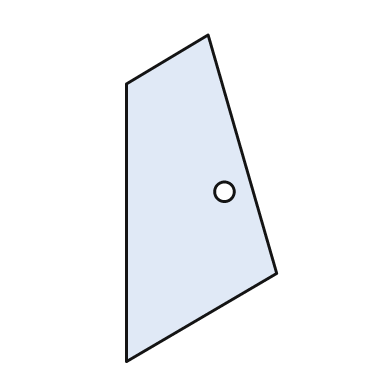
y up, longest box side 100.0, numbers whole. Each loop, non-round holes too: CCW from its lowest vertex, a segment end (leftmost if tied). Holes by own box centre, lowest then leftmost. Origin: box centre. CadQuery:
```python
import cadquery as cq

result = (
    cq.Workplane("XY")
    .moveTo(-23.0, -50.0)
    .lineTo(23.0, -23.0)
    .lineTo(2.0, 50.0)
    .lineTo(-23.0, 35.0)
    .close()
    .moveTo(7.0, 2.0)
    .circle(3.0)
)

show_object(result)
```